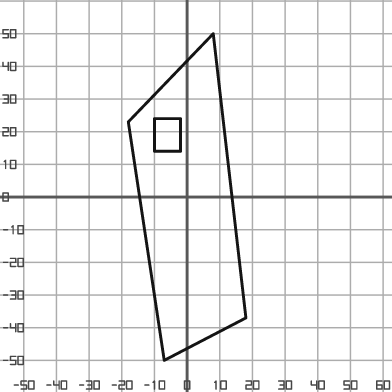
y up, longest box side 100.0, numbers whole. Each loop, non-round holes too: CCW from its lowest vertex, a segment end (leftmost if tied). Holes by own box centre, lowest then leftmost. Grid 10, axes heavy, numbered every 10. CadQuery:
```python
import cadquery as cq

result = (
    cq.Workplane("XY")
    .moveTo(-7.0, -50.0)
    .lineTo(18.0, -37.0)
    .lineTo(8.0, 50.0)
    .lineTo(-18.0, 23.0)
    .close()
    .moveTo(-10.0, 14.0)
    .lineTo(-2.0, 14.0)
    .lineTo(-2.0, 24.0)
    .lineTo(-10.0, 24.0)
    .close()
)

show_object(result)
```